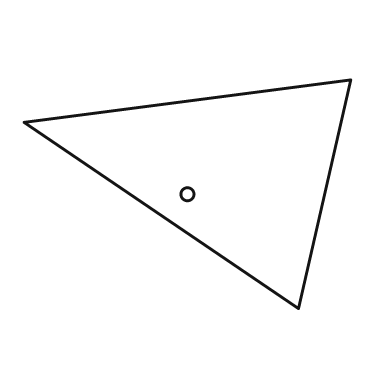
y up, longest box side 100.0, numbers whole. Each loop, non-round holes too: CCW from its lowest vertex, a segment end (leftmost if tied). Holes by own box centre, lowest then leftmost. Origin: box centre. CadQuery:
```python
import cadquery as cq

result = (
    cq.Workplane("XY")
    .moveTo(34.0, -35.0)
    .lineTo(50.0, 35.0)
    .lineTo(-50.0, 22.0)
    .close()
    .moveTo(0.0, 0.0)
    .circle(2.0)
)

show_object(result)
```